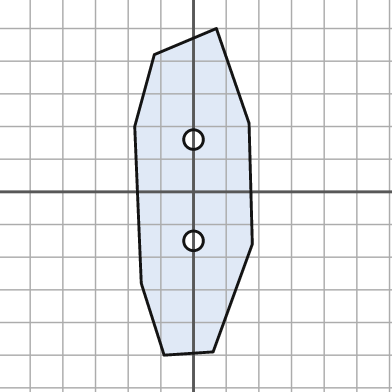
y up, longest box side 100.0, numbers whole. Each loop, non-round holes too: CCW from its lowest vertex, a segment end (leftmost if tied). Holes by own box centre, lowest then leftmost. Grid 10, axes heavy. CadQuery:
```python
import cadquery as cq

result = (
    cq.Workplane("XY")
    .moveTo(-9.0, -50.0)
    .lineTo(6.0, -49.0)
    .lineTo(18.0, -16.0)
    .lineTo(17.0, 21.0)
    .lineTo(7.0, 50.0)
    .lineTo(-12.0, 42.0)
    .lineTo(-18.0, 20.0)
    .lineTo(-16.0, -28.0)
    .close()
    .moveTo(0.0, -15.0)
    .circle(3.0)
    .moveTo(0.0, 16.0)
    .circle(3.0)
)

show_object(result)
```